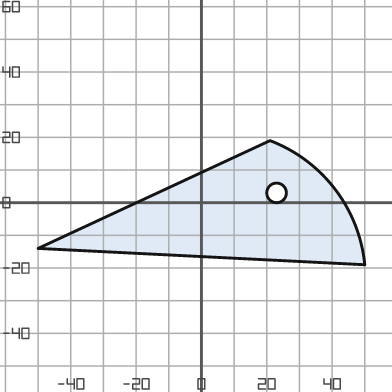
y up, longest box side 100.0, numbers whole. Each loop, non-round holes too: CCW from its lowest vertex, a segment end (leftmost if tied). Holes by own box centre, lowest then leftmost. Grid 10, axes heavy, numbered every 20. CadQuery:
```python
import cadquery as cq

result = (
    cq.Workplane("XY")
    .moveTo(50.0, -19.0)
    .threePointArc((41.0, 4.0), (21.0, 19.0))
    .lineTo(-50.0, -14.0)
    .close()
    .moveTo(23.0, 3.0)
    .circle(3.0)
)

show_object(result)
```